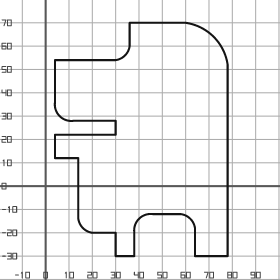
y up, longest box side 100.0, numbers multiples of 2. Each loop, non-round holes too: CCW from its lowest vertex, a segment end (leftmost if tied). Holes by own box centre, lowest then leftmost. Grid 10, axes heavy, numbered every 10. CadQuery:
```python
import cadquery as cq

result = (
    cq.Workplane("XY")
    .moveTo(30.0, -30.0)
    .lineTo(38.0, -30.0)
    .lineTo(38.0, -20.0)
    .threePointArc((40.0, -14.0), (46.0, -12.0))
    .lineTo(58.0, -12.0)
    .threePointArc((62.0, -14.0), (64.0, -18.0))
    .lineTo(64.0, -30.0)
    .lineTo(78.0, -30.0)
    .lineTo(78.0, 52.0)
    .threePointArc((72.0, 64.0), (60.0, 70.0))
    .lineTo(36.0, 70.0)
    .lineTo(36.0, 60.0)
    .threePointArc((34.0, 56.0), (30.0, 54.0))
    .lineTo(4.0, 54.0)
    .lineTo(4.0, 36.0)
    .threePointArc((6.0, 30.0), (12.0, 28.0))
    .lineTo(30.0, 28.0)
    .lineTo(30.0, 22.0)
    .lineTo(4.0, 22.0)
    .lineTo(4.0, 12.0)
    .lineTo(14.0, 12.0)
    .lineTo(14.0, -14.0)
    .threePointArc((16.0, -18.0), (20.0, -20.0))
    .lineTo(30.0, -20.0)
    .close()
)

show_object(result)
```